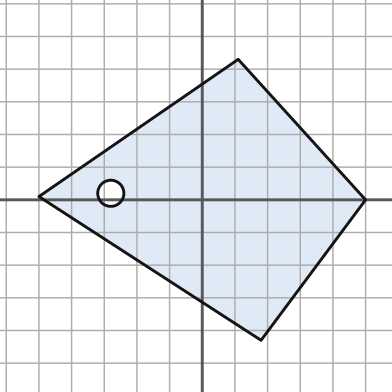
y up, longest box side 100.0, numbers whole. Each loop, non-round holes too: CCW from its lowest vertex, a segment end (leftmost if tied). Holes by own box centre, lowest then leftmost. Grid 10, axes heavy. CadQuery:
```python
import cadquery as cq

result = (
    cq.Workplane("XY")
    .moveTo(18.0, -43.0)
    .lineTo(50.0, 0.0)
    .lineTo(11.0, 43.0)
    .lineTo(-50.0, 1.0)
    .close()
    .moveTo(-28.0, 2.0)
    .circle(4.0)
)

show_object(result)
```